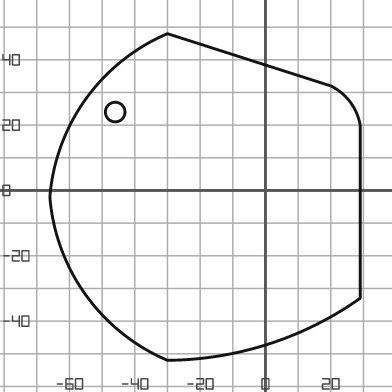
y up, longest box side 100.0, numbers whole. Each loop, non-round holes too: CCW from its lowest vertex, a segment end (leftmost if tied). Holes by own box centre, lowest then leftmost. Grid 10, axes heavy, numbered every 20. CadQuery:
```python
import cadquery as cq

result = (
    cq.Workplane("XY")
    .moveTo(-30.0, -52.0)
    .threePointArc((1.0, -47.0), (29.0, -33.0))
    .lineTo(29.0, 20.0)
    .threePointArc((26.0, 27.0), (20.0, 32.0))
    .lineTo(-30.0, 48.0)
    .threePointArc((-55.0, 28.0), (-66.0, -2.0))
    .threePointArc((-55.0, -32.0), (-30.0, -52.0))
    .close()
    .moveTo(-46.0, 24.0)
    .circle(3.0)
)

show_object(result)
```